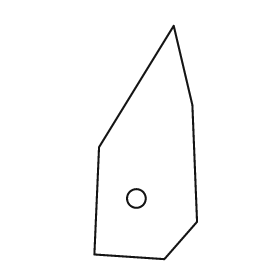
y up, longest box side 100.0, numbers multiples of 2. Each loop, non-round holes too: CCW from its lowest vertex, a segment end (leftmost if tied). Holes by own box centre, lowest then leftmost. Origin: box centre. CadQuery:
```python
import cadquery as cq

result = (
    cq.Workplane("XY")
    .moveTo(8.0, -50.0)
    .lineTo(22.0, -34.0)
    .lineTo(20.0, 16.0)
    .lineTo(12.0, 50.0)
    .lineTo(-20.0, -2.0)
    .lineTo(-22.0, -48.0)
    .close()
    .moveTo(-4.0, -24.0)
    .circle(4.0)
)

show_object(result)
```